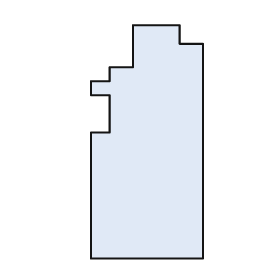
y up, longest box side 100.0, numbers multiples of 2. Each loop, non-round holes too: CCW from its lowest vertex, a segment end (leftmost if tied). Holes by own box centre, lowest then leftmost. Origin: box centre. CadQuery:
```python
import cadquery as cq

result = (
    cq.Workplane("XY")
    .moveTo(-24.0, -50.0)
    .lineTo(24.0, -50.0)
    .lineTo(24.0, 42.0)
    .lineTo(14.0, 42.0)
    .lineTo(14.0, 50.0)
    .lineTo(-6.0, 50.0)
    .lineTo(-6.0, 32.0)
    .lineTo(-16.0, 32.0)
    .lineTo(-16.0, 26.0)
    .lineTo(-24.0, 26.0)
    .lineTo(-24.0, 20.0)
    .lineTo(-16.0, 20.0)
    .lineTo(-16.0, 4.0)
    .lineTo(-24.0, 4.0)
    .close()
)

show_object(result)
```